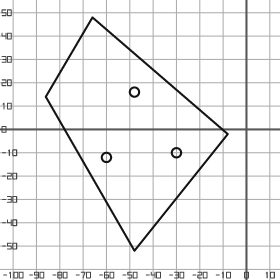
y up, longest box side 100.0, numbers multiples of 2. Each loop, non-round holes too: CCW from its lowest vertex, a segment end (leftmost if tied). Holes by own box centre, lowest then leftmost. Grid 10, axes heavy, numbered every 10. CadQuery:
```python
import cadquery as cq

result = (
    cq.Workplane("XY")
    .moveTo(-48.0, -52.0)
    .lineTo(-8.0, -2.0)
    .lineTo(-66.0, 48.0)
    .lineTo(-86.0, 14.0)
    .close()
    .moveTo(-60.0, -12.0)
    .circle(2.0)
    .moveTo(-30.0, -10.0)
    .circle(2.0)
    .moveTo(-48.0, 16.0)
    .circle(2.0)
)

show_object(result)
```